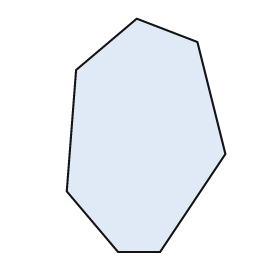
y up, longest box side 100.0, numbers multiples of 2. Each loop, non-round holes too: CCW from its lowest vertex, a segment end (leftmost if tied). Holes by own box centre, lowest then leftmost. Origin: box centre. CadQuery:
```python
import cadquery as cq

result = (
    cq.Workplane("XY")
    .moveTo(-12.0, -50.0)
    .lineTo(6.0, -50.0)
    .lineTo(34.0, -8.0)
    .lineTo(22.0, 40.0)
    .lineTo(-4.0, 50.0)
    .lineTo(-30.0, 28.0)
    .lineTo(-34.0, -24.0)
    .close()
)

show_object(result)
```